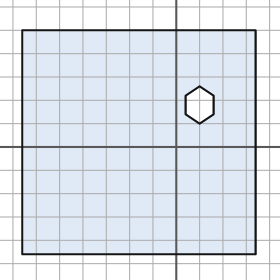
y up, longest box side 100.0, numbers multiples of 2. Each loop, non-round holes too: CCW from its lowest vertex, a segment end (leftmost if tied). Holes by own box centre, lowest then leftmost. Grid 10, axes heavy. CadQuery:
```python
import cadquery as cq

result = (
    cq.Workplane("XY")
    .moveTo(-66.0, -46.0)
    .lineTo(34.0, -46.0)
    .lineTo(34.0, 50.0)
    .lineTo(-66.0, 50.0)
    .close()
    .moveTo(10.0, 10.0)
    .lineTo(16.0, 14.0)
    .lineTo(16.0, 22.0)
    .lineTo(10.0, 26.0)
    .lineTo(4.0, 22.0)
    .lineTo(4.0, 14.0)
    .close()
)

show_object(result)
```